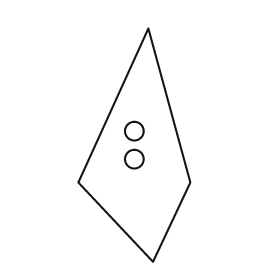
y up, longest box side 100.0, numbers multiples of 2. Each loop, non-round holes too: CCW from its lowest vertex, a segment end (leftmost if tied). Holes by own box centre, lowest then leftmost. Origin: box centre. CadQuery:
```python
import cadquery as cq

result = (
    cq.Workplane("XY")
    .moveTo(8.0, -50.0)
    .lineTo(24.0, -16.0)
    .lineTo(6.0, 50.0)
    .lineTo(-24.0, -16.0)
    .close()
    .moveTo(0.0, -6.0)
    .circle(4.0)
    .moveTo(0.0, 6.0)
    .circle(4.0)
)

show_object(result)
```